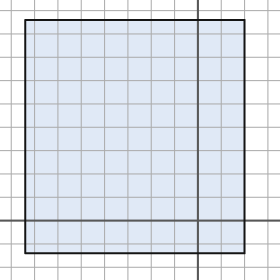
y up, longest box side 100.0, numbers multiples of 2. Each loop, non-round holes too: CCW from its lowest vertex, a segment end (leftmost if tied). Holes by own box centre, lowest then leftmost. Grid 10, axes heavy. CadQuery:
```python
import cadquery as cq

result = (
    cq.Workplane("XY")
    .moveTo(-74.0, -14.0)
    .lineTo(20.0, -14.0)
    .lineTo(20.0, 86.0)
    .lineTo(-74.0, 86.0)
    .close()
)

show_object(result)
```